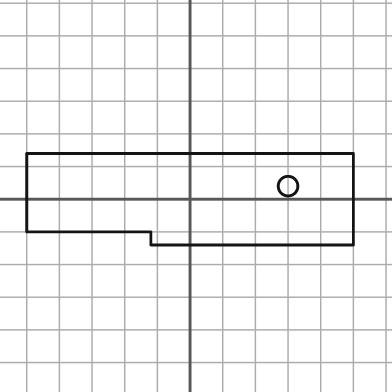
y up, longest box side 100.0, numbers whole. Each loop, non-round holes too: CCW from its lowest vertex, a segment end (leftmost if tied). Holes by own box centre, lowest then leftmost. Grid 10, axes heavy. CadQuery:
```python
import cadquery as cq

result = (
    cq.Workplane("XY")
    .moveTo(-12.0, -14.0)
    .lineTo(50.0, -14.0)
    .lineTo(50.0, 14.0)
    .lineTo(-50.0, 14.0)
    .lineTo(-50.0, -10.0)
    .lineTo(-12.0, -10.0)
    .close()
    .moveTo(30.0, 4.0)
    .circle(3.0)
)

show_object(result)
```